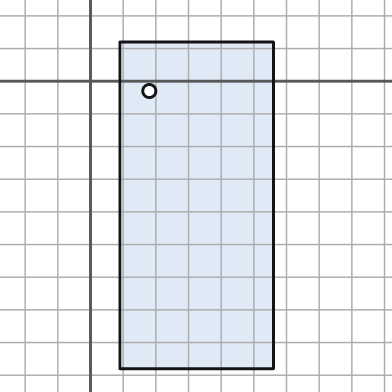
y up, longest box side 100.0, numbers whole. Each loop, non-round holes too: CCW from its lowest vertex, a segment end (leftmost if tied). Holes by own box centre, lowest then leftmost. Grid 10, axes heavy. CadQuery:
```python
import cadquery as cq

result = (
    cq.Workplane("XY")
    .moveTo(9.0, -88.0)
    .lineTo(56.0, -88.0)
    .lineTo(56.0, 12.0)
    .lineTo(9.0, 12.0)
    .close()
    .moveTo(18.0, -3.0)
    .circle(2.0)
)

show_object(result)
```